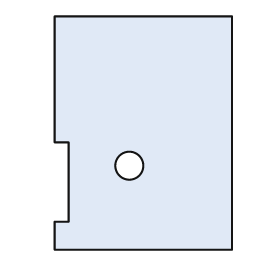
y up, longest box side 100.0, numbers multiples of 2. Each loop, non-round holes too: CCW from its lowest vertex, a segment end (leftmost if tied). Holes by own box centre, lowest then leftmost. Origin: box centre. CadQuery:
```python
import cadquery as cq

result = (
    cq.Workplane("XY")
    .moveTo(-38.0, -50.0)
    .lineTo(38.0, -50.0)
    .lineTo(38.0, 50.0)
    .lineTo(-38.0, 50.0)
    .lineTo(-38.0, -4.0)
    .lineTo(-32.0, -4.0)
    .lineTo(-32.0, -38.0)
    .lineTo(-38.0, -38.0)
    .close()
    .moveTo(-6.0, -14.0)
    .circle(6.0)
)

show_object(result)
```